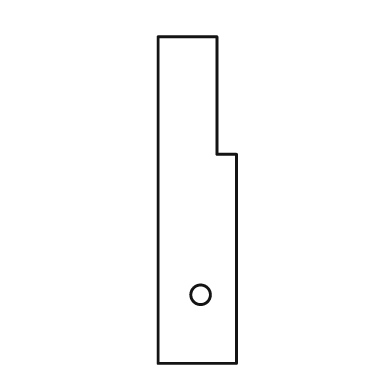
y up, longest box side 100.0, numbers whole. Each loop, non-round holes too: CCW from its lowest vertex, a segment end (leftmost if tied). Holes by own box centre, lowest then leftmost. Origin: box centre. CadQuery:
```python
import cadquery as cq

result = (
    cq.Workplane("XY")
    .moveTo(-12.0, -50.0)
    .lineTo(12.0, -50.0)
    .lineTo(12.0, 14.0)
    .lineTo(6.0, 14.0)
    .lineTo(6.0, 50.0)
    .lineTo(-12.0, 50.0)
    .close()
    .moveTo(1.0, -29.0)
    .circle(3.0)
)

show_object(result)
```